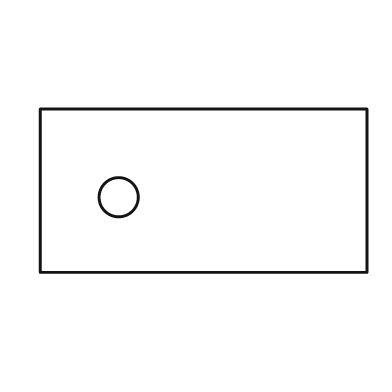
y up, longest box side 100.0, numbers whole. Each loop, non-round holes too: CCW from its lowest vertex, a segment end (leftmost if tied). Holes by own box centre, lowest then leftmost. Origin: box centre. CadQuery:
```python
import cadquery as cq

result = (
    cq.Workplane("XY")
    .moveTo(-50.0, -25.0)
    .lineTo(50.0, -25.0)
    .lineTo(50.0, 25.0)
    .lineTo(-50.0, 25.0)
    .close()
    .moveTo(-26.0, -2.0)
    .circle(6.0)
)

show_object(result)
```